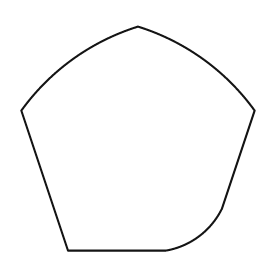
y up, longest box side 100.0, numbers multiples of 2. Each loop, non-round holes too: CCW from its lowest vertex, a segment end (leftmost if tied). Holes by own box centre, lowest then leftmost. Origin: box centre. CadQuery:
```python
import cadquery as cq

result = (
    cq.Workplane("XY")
    .moveTo(-30.0, -48.0)
    .lineTo(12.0, -48.0)
    .threePointArc((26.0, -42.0), (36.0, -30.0))
    .lineTo(50.0, 12.0)
    .threePointArc((28.0, 34.0), (0.0, 48.0))
    .threePointArc((-28.0, 34.0), (-50.0, 12.0))
    .close()
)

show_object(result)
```